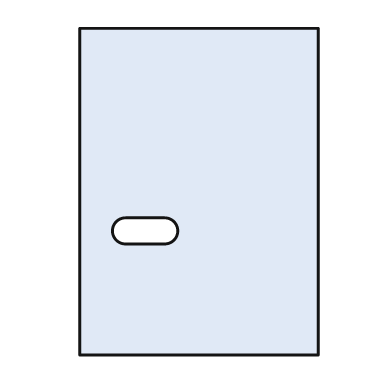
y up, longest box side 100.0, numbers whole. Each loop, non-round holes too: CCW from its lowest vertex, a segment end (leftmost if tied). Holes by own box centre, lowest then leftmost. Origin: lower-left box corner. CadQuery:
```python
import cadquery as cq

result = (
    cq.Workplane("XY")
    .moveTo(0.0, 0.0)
    .lineTo(73.0, 0.0)
    .lineTo(73.0, 100.0)
    .lineTo(0.0, 100.0)
    .close()
    .moveTo(14.0, 34.0)
    .lineTo(26.0, 34.0)
    .threePointArc((30.0, 38.0), (26.0, 42.0))
    .lineTo(14.0, 42.0)
    .threePointArc((10.0, 38.0), (14.0, 34.0))
    .close()
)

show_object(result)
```